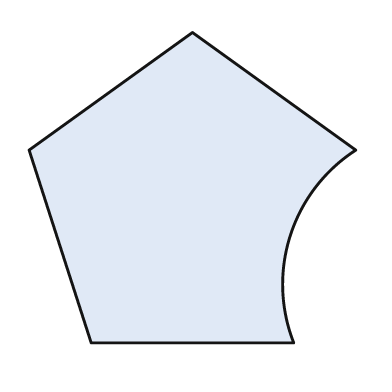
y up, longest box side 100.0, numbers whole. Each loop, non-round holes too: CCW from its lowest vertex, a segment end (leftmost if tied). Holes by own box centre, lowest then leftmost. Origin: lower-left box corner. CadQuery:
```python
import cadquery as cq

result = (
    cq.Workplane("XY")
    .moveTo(19.0, 0.0)
    .lineTo(81.0, 0.0)
    .threePointArc((80.0, 33.0), (100.0, 59.0))
    .lineTo(50.0, 95.0)
    .lineTo(0.0, 59.0)
    .close()
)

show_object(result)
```